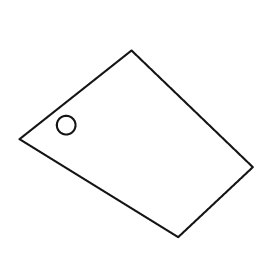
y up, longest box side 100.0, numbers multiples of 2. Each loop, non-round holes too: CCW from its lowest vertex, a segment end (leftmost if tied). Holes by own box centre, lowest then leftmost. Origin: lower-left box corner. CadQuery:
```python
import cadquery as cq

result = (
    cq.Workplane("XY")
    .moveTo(68.0, 0.0)
    .lineTo(100.0, 30.0)
    .lineTo(48.0, 80.0)
    .lineTo(0.0, 42.0)
    .close()
    .moveTo(20.0, 48.0)
    .circle(4.0)
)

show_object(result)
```